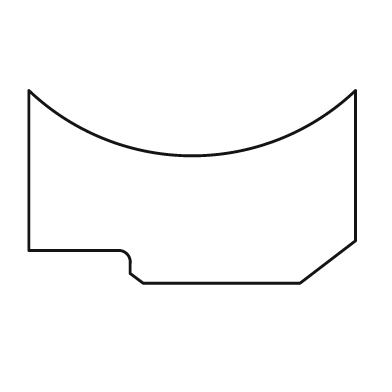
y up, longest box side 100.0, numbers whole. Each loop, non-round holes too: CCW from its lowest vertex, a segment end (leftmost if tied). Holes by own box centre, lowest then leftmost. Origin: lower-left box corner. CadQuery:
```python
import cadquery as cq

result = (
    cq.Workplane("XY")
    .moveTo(35.0, 0.0)
    .lineTo(83.0, 0.0)
    .lineTo(100.0, 13.0)
    .lineTo(100.0, 59.0)
    .threePointArc((50.0, 39.0), (0.0, 59.0))
    .lineTo(0.0, 10.0)
    .lineTo(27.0, 10.0)
    .threePointArc((30.0, 9.0), (31.0, 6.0))
    .lineTo(31.0, 3.0)
    .close()
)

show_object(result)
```